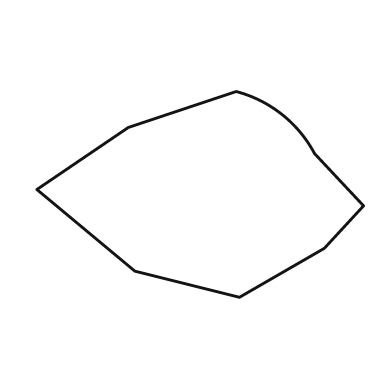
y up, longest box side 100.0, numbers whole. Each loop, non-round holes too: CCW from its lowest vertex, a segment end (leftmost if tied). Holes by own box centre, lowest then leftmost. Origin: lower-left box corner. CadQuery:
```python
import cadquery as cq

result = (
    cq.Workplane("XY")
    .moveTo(62.0, 0.0)
    .lineTo(88.0, 15.0)
    .lineTo(100.0, 28.0)
    .lineTo(85.0, 44.0)
    .threePointArc((75.0, 56.0), (61.0, 63.0))
    .lineTo(28.0, 52.0)
    .lineTo(0.0, 33.0)
    .lineTo(30.0, 8.0)
    .close()
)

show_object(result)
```